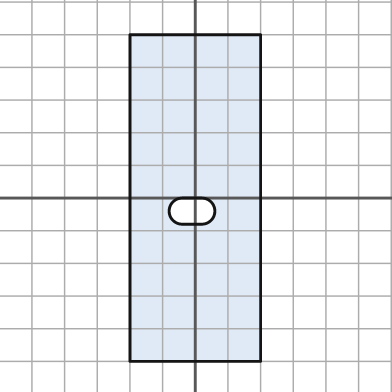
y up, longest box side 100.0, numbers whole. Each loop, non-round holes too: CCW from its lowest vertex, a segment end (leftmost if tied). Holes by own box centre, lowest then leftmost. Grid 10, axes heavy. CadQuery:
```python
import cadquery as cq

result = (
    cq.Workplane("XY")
    .moveTo(-20.0, -50.0)
    .lineTo(20.0, -50.0)
    .lineTo(20.0, 50.0)
    .lineTo(-20.0, 50.0)
    .close()
    .moveTo(-4.0, -8.0)
    .lineTo(2.0, -8.0)
    .threePointArc((6.0, -4.0), (2.0, 0.0))
    .lineTo(-4.0, 0.0)
    .threePointArc((-8.0, -4.0), (-4.0, -8.0))
    .close()
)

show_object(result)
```